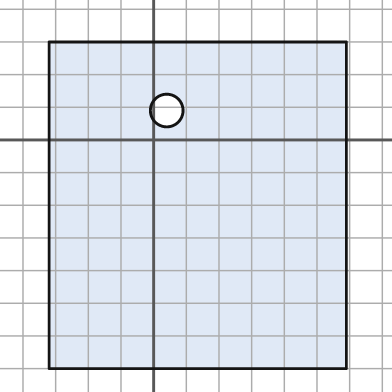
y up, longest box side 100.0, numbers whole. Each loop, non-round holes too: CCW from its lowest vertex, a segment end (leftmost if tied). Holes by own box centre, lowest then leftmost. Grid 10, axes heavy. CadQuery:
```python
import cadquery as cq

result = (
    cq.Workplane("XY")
    .moveTo(-32.0, -70.0)
    .lineTo(59.0, -70.0)
    .lineTo(59.0, 30.0)
    .lineTo(-32.0, 30.0)
    .close()
    .moveTo(4.0, 9.0)
    .circle(5.0)
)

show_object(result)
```